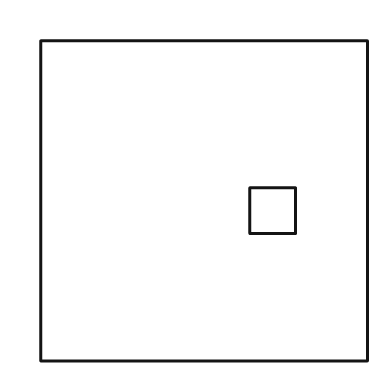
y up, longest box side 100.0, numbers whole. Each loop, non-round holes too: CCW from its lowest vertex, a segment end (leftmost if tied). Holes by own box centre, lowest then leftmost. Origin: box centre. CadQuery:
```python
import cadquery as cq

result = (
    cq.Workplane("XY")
    .moveTo(-50.0, -49.0)
    .lineTo(50.0, -49.0)
    .lineTo(50.0, 49.0)
    .lineTo(-50.0, 49.0)
    .close()
    .moveTo(14.0, -10.0)
    .lineTo(28.0, -10.0)
    .lineTo(28.0, 4.0)
    .lineTo(14.0, 4.0)
    .close()
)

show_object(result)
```